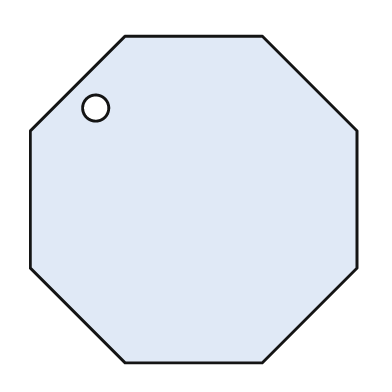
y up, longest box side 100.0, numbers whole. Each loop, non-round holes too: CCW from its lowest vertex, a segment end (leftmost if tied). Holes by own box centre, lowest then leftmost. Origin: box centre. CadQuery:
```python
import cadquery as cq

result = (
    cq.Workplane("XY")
    .moveTo(-21.0, -50.0)
    .lineTo(21.0, -50.0)
    .lineTo(50.0, -21.0)
    .lineTo(50.0, 21.0)
    .lineTo(21.0, 50.0)
    .lineTo(-21.0, 50.0)
    .lineTo(-50.0, 21.0)
    .lineTo(-50.0, -21.0)
    .close()
    .moveTo(-30.0, 28.0)
    .circle(4.0)
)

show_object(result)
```